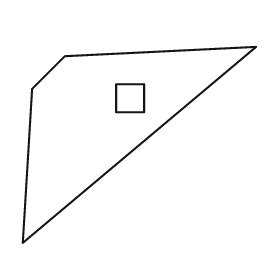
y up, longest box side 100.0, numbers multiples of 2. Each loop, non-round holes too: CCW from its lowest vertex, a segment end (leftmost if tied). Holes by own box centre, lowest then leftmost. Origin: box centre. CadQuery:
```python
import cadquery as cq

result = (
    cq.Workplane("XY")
    .moveTo(-50.0, -42.0)
    .lineTo(50.0, 42.0)
    .lineTo(-32.0, 38.0)
    .lineTo(-46.0, 24.0)
    .close()
    .moveTo(-10.0, 14.0)
    .lineTo(2.0, 14.0)
    .lineTo(2.0, 26.0)
    .lineTo(-10.0, 26.0)
    .close()
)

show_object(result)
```